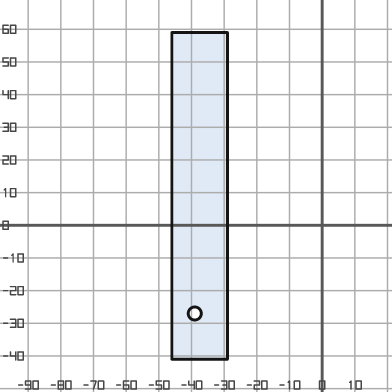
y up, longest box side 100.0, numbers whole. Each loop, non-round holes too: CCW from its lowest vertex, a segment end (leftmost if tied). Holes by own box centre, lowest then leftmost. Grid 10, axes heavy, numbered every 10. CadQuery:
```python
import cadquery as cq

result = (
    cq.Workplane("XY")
    .moveTo(-46.0, -41.0)
    .lineTo(-29.0, -41.0)
    .lineTo(-29.0, 59.0)
    .lineTo(-46.0, 59.0)
    .close()
    .moveTo(-39.0, -27.0)
    .circle(2.0)
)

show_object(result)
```